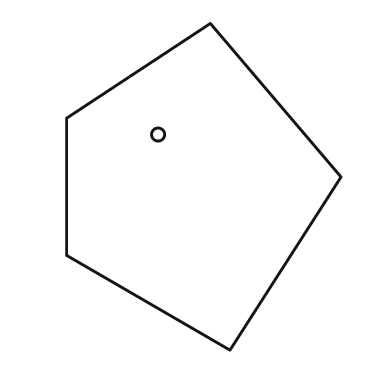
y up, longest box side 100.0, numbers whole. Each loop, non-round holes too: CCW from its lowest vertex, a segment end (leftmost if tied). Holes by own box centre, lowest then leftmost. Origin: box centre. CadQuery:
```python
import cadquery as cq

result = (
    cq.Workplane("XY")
    .moveTo(8.0, -50.0)
    .lineTo(42.0, 3.0)
    .lineTo(2.0, 50.0)
    .lineTo(-42.0, 21.0)
    .lineTo(-42.0, -21.0)
    .close()
    .moveTo(-14.0, 16.0)
    .circle(2.0)
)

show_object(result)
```